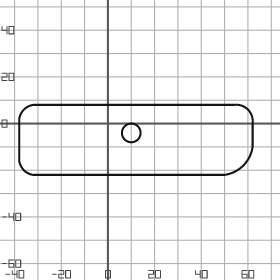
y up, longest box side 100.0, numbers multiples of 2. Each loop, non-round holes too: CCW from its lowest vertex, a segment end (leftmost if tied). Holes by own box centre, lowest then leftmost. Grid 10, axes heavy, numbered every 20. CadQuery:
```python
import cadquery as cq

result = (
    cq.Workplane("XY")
    .moveTo(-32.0, -22.0)
    .lineTo(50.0, -22.0)
    .threePointArc((58.0, -18.0), (62.0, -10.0))
    .lineTo(62.0, 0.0)
    .threePointArc((60.0, 6.0), (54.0, 8.0))
    .lineTo(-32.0, 8.0)
    .threePointArc((-36.0, 6.0), (-38.0, 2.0))
    .lineTo(-38.0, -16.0)
    .threePointArc((-36.0, -20.0), (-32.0, -22.0))
    .close()
    .moveTo(10.0, -4.0)
    .circle(4.0)
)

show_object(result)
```